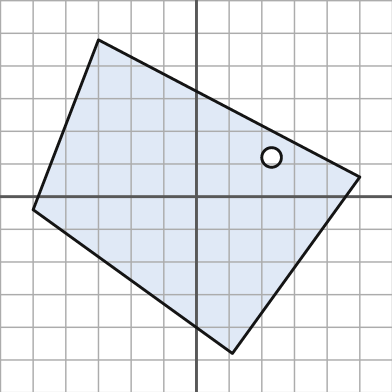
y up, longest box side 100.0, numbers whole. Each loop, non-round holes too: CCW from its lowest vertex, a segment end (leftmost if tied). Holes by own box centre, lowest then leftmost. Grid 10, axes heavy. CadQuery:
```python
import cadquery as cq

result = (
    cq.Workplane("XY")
    .moveTo(11.0, -48.0)
    .lineTo(50.0, 6.0)
    .lineTo(-30.0, 48.0)
    .lineTo(-50.0, -4.0)
    .close()
    .moveTo(23.0, 12.0)
    .circle(3.0)
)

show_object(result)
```